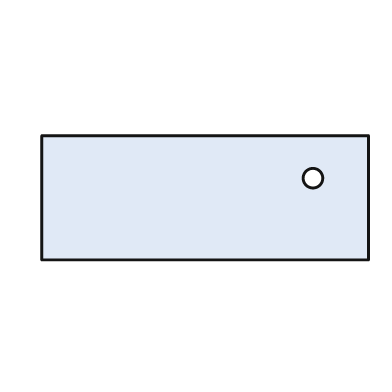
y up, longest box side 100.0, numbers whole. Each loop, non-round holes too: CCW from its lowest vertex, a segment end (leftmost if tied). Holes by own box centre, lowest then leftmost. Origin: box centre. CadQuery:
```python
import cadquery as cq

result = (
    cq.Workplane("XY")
    .moveTo(-50.0, -19.0)
    .lineTo(50.0, -19.0)
    .lineTo(50.0, 19.0)
    .lineTo(-50.0, 19.0)
    .close()
    .moveTo(33.0, 6.0)
    .circle(3.0)
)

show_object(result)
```